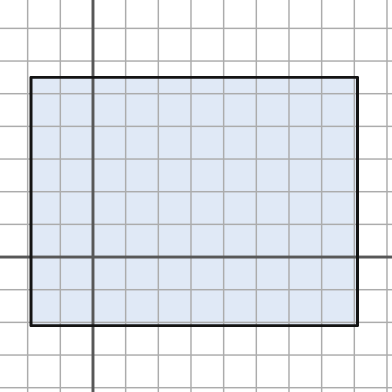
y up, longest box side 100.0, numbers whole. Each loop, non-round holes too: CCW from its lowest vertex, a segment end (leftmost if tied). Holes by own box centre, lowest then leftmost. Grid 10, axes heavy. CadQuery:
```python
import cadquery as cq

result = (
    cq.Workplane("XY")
    .moveTo(-19.0, -21.0)
    .lineTo(81.0, -21.0)
    .lineTo(81.0, 55.0)
    .lineTo(-19.0, 55.0)
    .close()
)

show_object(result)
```